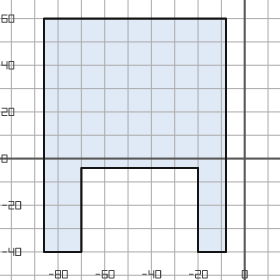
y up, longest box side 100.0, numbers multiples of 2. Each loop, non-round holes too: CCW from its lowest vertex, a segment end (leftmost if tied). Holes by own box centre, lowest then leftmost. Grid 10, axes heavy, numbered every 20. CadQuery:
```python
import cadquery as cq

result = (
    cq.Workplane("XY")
    .moveTo(-86.0, -40.0)
    .lineTo(-70.0, -40.0)
    .lineTo(-70.0, -4.0)
    .lineTo(-20.0, -4.0)
    .lineTo(-20.0, -40.0)
    .lineTo(-8.0, -40.0)
    .lineTo(-8.0, 60.0)
    .lineTo(-86.0, 60.0)
    .close()
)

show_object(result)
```